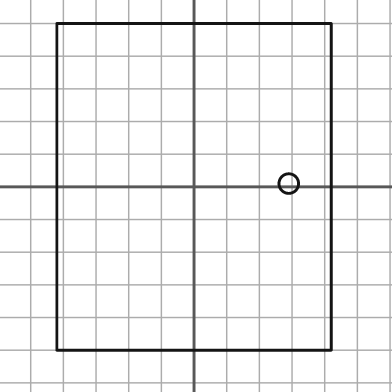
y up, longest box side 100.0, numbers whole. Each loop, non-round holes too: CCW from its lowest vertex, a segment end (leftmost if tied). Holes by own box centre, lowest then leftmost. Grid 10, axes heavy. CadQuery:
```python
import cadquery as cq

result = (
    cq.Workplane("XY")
    .moveTo(-42.0, -50.0)
    .lineTo(42.0, -50.0)
    .lineTo(42.0, 50.0)
    .lineTo(-42.0, 50.0)
    .close()
    .moveTo(29.0, 1.0)
    .circle(3.0)
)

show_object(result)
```